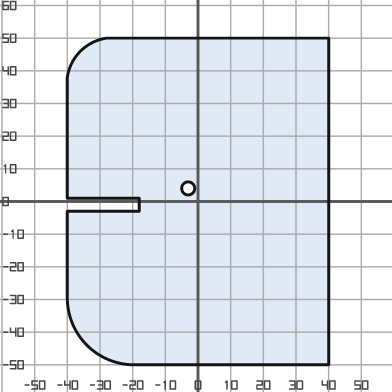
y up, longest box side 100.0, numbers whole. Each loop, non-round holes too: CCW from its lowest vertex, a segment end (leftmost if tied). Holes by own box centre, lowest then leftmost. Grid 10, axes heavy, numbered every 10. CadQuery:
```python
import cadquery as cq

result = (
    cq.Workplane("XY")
    .moveTo(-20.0, -50.0)
    .lineTo(40.0, -50.0)
    .lineTo(40.0, 50.0)
    .lineTo(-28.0, 50.0)
    .threePointArc((-36.0, 46.0), (-40.0, 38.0))
    .lineTo(-40.0, 1.0)
    .lineTo(-18.0, 1.0)
    .lineTo(-18.0, -3.0)
    .lineTo(-40.0, -3.0)
    .lineTo(-40.0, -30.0)
    .threePointArc((-34.0, -44.0), (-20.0, -50.0))
    .close()
    .moveTo(-3.0, 4.0)
    .circle(2.0)
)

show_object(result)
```